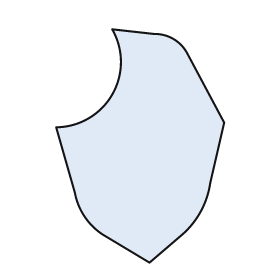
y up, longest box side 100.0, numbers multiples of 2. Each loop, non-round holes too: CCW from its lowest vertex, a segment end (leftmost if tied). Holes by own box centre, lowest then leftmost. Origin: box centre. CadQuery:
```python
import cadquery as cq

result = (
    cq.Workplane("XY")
    .moveTo(4.0, -50.0)
    .lineTo(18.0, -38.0)
    .threePointArc((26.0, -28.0), (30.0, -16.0))
    .lineTo(36.0, 10.0)
    .lineTo(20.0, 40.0)
    .threePointArc((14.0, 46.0), (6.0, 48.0))
    .lineTo(-12.0, 50.0)
    .threePointArc((-12.0, 22.0), (-36.0, 8.0))
    .lineTo(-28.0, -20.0)
    .threePointArc((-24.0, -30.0), (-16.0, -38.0))
    .close()
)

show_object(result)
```